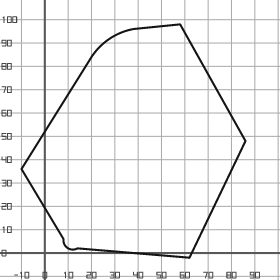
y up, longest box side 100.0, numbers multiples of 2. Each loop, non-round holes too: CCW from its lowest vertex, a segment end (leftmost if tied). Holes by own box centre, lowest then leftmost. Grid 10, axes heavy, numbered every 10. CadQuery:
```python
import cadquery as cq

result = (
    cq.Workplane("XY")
    .moveTo(62.0, -2.0)
    .lineTo(86.0, 48.0)
    .lineTo(58.0, 98.0)
    .lineTo(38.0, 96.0)
    .threePointArc((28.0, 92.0), (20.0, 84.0))
    .lineTo(-10.0, 36.0)
    .lineTo(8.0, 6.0)
    .threePointArc((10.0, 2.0), (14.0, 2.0))
    .close()
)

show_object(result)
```